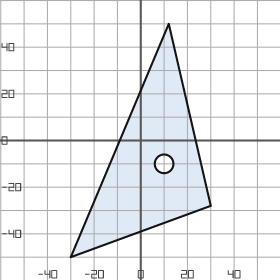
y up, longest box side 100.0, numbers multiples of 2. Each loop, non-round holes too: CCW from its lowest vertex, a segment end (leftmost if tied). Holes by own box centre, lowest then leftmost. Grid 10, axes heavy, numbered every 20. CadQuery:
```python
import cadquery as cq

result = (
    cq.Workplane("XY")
    .moveTo(-30.0, -50.0)
    .lineTo(30.0, -28.0)
    .lineTo(12.0, 50.0)
    .close()
    .moveTo(10.0, -10.0)
    .circle(4.0)
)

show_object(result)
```